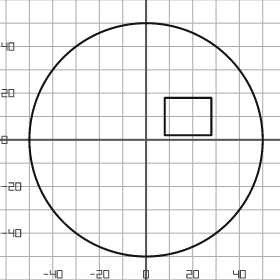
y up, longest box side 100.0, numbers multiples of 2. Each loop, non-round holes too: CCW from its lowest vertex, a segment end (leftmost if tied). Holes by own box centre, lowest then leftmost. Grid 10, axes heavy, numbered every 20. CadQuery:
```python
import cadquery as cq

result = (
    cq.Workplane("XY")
    .moveTo(0.0, 0.0)
    .circle(50.0)
    .moveTo(8.0, 2.0)
    .lineTo(28.0, 2.0)
    .lineTo(28.0, 18.0)
    .lineTo(8.0, 18.0)
    .close()
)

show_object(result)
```